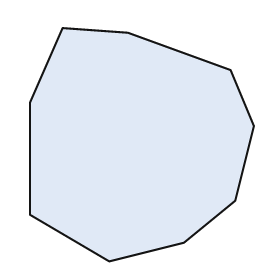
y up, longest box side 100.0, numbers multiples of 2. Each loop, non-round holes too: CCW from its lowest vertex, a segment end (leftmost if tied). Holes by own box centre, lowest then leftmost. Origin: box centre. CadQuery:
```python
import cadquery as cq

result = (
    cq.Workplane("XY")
    .moveTo(-14.0, -50.0)
    .lineTo(18.0, -42.0)
    .lineTo(40.0, -24.0)
    .lineTo(48.0, 8.0)
    .lineTo(38.0, 32.0)
    .lineTo(-6.0, 48.0)
    .lineTo(-34.0, 50.0)
    .lineTo(-48.0, 18.0)
    .lineTo(-48.0, -30.0)
    .close()
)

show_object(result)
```